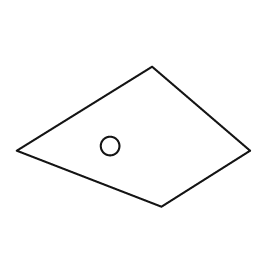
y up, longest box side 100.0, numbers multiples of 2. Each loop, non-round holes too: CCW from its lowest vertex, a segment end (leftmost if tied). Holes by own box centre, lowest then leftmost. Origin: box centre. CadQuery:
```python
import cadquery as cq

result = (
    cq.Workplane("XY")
    .moveTo(12.0, -30.0)
    .lineTo(50.0, -6.0)
    .lineTo(8.0, 30.0)
    .lineTo(-50.0, -6.0)
    .close()
    .moveTo(-10.0, -4.0)
    .circle(4.0)
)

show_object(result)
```